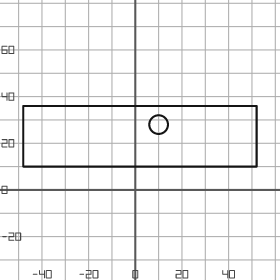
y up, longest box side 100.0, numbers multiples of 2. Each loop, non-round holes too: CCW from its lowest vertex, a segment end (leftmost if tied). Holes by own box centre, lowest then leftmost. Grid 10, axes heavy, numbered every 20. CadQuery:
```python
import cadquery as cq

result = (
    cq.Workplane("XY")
    .moveTo(-48.0, 10.0)
    .lineTo(52.0, 10.0)
    .lineTo(52.0, 36.0)
    .lineTo(-48.0, 36.0)
    .close()
    .moveTo(10.0, 28.0)
    .circle(4.0)
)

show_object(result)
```